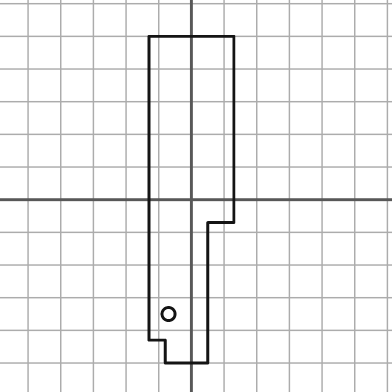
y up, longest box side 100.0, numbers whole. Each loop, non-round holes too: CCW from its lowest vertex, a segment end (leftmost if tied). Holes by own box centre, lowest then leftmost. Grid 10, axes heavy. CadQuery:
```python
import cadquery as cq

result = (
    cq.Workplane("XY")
    .moveTo(-8.0, -50.0)
    .lineTo(5.0, -50.0)
    .lineTo(5.0, -7.0)
    .lineTo(13.0, -7.0)
    .lineTo(13.0, 50.0)
    .lineTo(-13.0, 50.0)
    .lineTo(-13.0, -43.0)
    .lineTo(-8.0, -43.0)
    .close()
    .moveTo(-7.0, -35.0)
    .circle(2.0)
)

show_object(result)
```